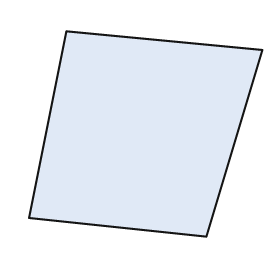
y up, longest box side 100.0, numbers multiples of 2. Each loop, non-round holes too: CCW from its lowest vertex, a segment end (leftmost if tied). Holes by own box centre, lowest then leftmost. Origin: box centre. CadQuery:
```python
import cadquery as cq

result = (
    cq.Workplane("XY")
    .moveTo(26.0, -44.0)
    .lineTo(50.0, 36.0)
    .lineTo(-34.0, 44.0)
    .lineTo(-50.0, -36.0)
    .close()
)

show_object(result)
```